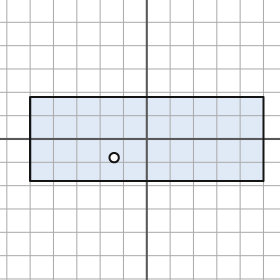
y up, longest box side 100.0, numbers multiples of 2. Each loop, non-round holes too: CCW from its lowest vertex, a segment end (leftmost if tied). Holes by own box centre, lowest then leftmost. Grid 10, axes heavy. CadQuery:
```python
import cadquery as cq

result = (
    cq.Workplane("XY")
    .moveTo(-50.0, -18.0)
    .lineTo(50.0, -18.0)
    .lineTo(50.0, 18.0)
    .lineTo(-50.0, 18.0)
    .close()
    .moveTo(-14.0, -8.0)
    .circle(2.0)
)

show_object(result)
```